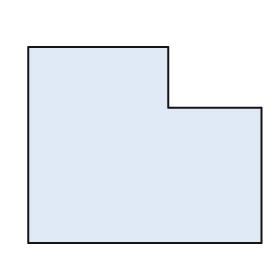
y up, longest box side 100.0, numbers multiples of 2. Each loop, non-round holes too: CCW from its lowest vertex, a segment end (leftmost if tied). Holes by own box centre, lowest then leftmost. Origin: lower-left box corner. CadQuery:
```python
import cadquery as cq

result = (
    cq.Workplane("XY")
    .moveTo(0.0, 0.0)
    .lineTo(100.0, 0.0)
    .lineTo(100.0, 58.0)
    .lineTo(60.0, 58.0)
    .lineTo(60.0, 84.0)
    .lineTo(0.0, 84.0)
    .close()
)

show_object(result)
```